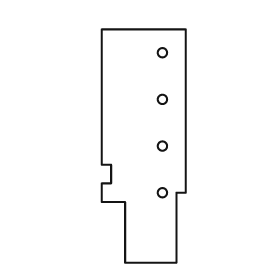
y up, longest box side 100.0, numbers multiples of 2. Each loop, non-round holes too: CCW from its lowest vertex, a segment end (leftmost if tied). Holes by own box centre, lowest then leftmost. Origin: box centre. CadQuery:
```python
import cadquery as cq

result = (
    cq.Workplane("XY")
    .moveTo(-8.0, -50.0)
    .lineTo(14.0, -50.0)
    .lineTo(14.0, -20.0)
    .lineTo(18.0, -20.0)
    .lineTo(18.0, 50.0)
    .lineTo(-18.0, 50.0)
    .lineTo(-18.0, -8.0)
    .lineTo(-14.0, -8.0)
    .lineTo(-14.0, -16.0)
    .lineTo(-18.0, -16.0)
    .lineTo(-18.0, -24.0)
    .lineTo(-8.0, -24.0)
    .close()
    .moveTo(8.0, -20.0)
    .circle(2.0)
    .moveTo(8.0, 0.0)
    .circle(2.0)
    .moveTo(8.0, 20.0)
    .circle(2.0)
    .moveTo(8.0, 40.0)
    .circle(2.0)
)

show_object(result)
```